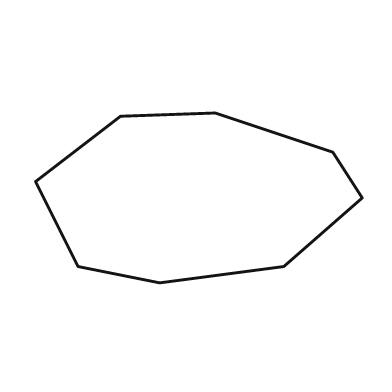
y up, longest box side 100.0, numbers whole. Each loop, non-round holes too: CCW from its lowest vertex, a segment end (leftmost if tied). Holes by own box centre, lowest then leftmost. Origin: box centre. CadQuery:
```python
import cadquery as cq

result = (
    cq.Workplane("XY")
    .moveTo(-12.0, -26.0)
    .lineTo(26.0, -21.0)
    .lineTo(50.0, 0.0)
    .lineTo(41.0, 14.0)
    .lineTo(5.0, 26.0)
    .lineTo(-24.0, 25.0)
    .lineTo(-50.0, 5.0)
    .lineTo(-37.0, -21.0)
    .close()
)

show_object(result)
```